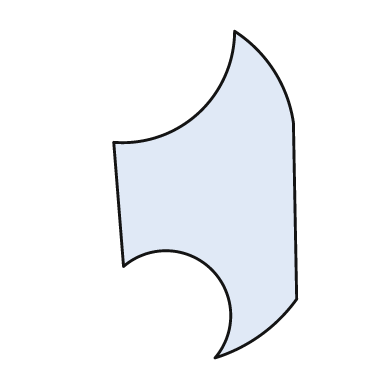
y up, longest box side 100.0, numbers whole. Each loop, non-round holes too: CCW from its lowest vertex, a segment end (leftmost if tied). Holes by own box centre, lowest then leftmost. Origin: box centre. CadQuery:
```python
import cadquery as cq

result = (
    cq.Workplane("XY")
    .moveTo(3.0, -50.0)
    .threePointArc((17.0, -43.0), (28.0, -32.0))
    .lineTo(27.0, 22.0)
    .threePointArc((21.0, 38.0), (9.0, 50.0))
    .threePointArc((-2.0, 25.0), (-28.0, 16.0))
    .lineTo(-25.0, -22.0)
    .threePointArc((2.0, -23.0), (3.0, -50.0))
    .close()
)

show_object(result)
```